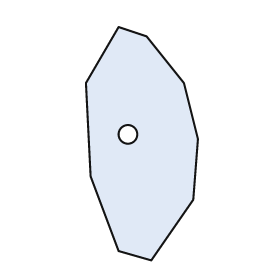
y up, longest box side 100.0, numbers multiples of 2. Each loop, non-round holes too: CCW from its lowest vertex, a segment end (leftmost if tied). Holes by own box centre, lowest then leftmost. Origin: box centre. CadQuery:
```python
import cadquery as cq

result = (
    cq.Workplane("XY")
    .moveTo(4.0, -50.0)
    .lineTo(22.0, -24.0)
    .lineTo(24.0, 2.0)
    .lineTo(18.0, 26.0)
    .lineTo(2.0, 46.0)
    .lineTo(-10.0, 50.0)
    .lineTo(-24.0, 26.0)
    .lineTo(-22.0, -14.0)
    .lineTo(-10.0, -46.0)
    .close()
    .moveTo(-6.0, 4.0)
    .circle(4.0)
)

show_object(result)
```